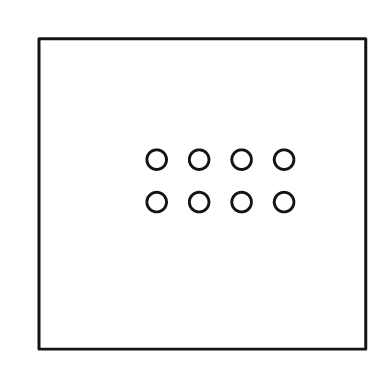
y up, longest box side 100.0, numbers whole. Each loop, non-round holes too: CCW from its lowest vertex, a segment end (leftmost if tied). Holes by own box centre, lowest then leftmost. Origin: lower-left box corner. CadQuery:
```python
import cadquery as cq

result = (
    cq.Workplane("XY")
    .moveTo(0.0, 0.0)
    .lineTo(100.0, 0.0)
    .lineTo(100.0, 95.0)
    .lineTo(0.0, 95.0)
    .close()
    .moveTo(36.0, 45.0)
    .circle(3.0)
    .moveTo(49.0, 45.0)
    .circle(3.0)
    .moveTo(62.0, 45.0)
    .circle(3.0)
    .moveTo(75.0, 45.0)
    .circle(3.0)
    .moveTo(36.0, 58.0)
    .circle(3.0)
    .moveTo(49.0, 58.0)
    .circle(3.0)
    .moveTo(62.0, 58.0)
    .circle(3.0)
    .moveTo(75.0, 58.0)
    .circle(3.0)
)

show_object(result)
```